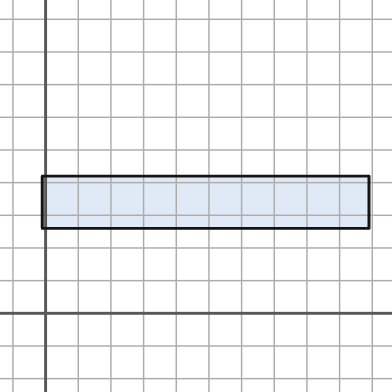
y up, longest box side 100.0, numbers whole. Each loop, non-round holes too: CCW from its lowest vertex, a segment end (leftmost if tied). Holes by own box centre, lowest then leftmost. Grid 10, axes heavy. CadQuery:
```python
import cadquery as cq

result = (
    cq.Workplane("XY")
    .moveTo(-1.0, 26.0)
    .lineTo(99.0, 26.0)
    .lineTo(99.0, 42.0)
    .lineTo(-1.0, 42.0)
    .close()
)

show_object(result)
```